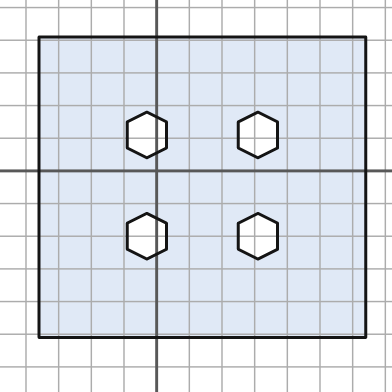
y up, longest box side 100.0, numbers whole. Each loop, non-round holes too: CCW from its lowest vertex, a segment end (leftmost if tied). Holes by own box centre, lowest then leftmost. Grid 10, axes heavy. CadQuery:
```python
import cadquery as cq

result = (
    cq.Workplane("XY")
    .moveTo(-36.0, -51.0)
    .lineTo(64.0, -51.0)
    .lineTo(64.0, 41.0)
    .lineTo(-36.0, 41.0)
    .close()
    .moveTo(-3.0, -27.0)
    .lineTo(3.0, -24.0)
    .lineTo(3.0, -16.0)
    .lineTo(-3.0, -13.0)
    .lineTo(-9.0, -16.0)
    .lineTo(-9.0, -24.0)
    .close()
    .moveTo(31.0, -27.0)
    .lineTo(37.0, -24.0)
    .lineTo(37.0, -16.0)
    .lineTo(31.0, -13.0)
    .lineTo(25.0, -16.0)
    .lineTo(25.0, -24.0)
    .close()
    .moveTo(-3.0, 4.0)
    .lineTo(3.0, 7.0)
    .lineTo(3.0, 15.0)
    .lineTo(-3.0, 18.0)
    .lineTo(-9.0, 15.0)
    .lineTo(-9.0, 7.0)
    .close()
    .moveTo(31.0, 4.0)
    .lineTo(37.0, 7.0)
    .lineTo(37.0, 15.0)
    .lineTo(31.0, 18.0)
    .lineTo(25.0, 15.0)
    .lineTo(25.0, 7.0)
    .close()
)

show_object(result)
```